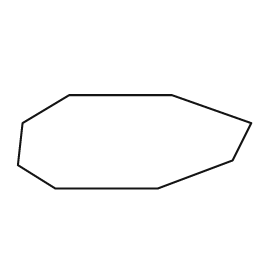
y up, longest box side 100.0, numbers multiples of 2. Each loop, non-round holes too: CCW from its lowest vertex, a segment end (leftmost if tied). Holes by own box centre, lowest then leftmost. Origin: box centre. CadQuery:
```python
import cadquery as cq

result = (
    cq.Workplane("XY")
    .moveTo(-34.0, -20.0)
    .lineTo(10.0, -20.0)
    .lineTo(42.0, -8.0)
    .lineTo(50.0, 8.0)
    .lineTo(16.0, 20.0)
    .lineTo(-28.0, 20.0)
    .lineTo(-48.0, 8.0)
    .lineTo(-50.0, -10.0)
    .close()
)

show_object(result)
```